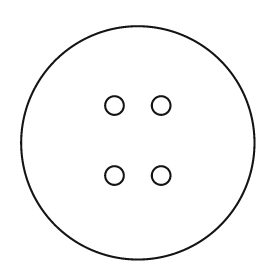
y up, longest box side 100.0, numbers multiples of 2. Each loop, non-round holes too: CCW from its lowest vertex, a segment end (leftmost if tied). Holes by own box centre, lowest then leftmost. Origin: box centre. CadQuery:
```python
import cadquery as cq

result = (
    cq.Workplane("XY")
    .moveTo(0.0, 0.0)
    .circle(50.0)
    .moveTo(-10.0, -14.0)
    .circle(4.0)
    .moveTo(10.0, -14.0)
    .circle(4.0)
    .moveTo(-10.0, 16.0)
    .circle(4.0)
    .moveTo(10.0, 16.0)
    .circle(4.0)
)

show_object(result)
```